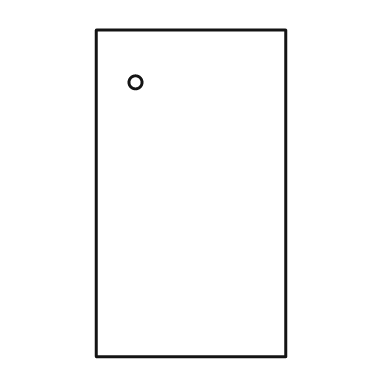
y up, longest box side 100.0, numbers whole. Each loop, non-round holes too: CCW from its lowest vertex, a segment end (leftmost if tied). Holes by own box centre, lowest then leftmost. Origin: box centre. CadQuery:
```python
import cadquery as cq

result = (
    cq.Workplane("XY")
    .moveTo(-29.0, -50.0)
    .lineTo(29.0, -50.0)
    .lineTo(29.0, 50.0)
    .lineTo(-29.0, 50.0)
    .close()
    .moveTo(-17.0, 34.0)
    .circle(2.0)
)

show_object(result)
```